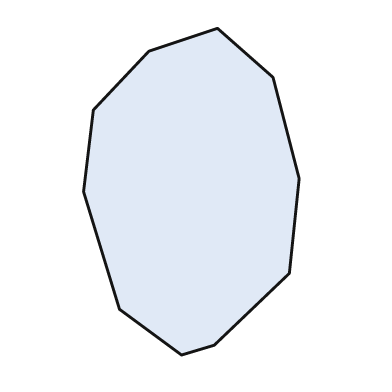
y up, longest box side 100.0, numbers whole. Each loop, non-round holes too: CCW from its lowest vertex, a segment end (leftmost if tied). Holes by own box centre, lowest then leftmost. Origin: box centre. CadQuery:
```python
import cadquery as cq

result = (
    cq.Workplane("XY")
    .moveTo(-3.0, -50.0)
    .lineTo(7.0, -47.0)
    .lineTo(30.0, -25.0)
    .lineTo(33.0, 4.0)
    .lineTo(25.0, 35.0)
    .lineTo(8.0, 50.0)
    .lineTo(-13.0, 43.0)
    .lineTo(-30.0, 25.0)
    .lineTo(-33.0, 0.0)
    .lineTo(-22.0, -36.0)
    .close()
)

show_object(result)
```